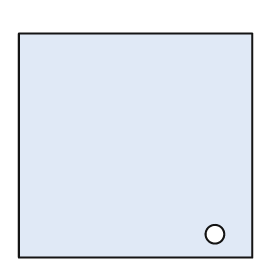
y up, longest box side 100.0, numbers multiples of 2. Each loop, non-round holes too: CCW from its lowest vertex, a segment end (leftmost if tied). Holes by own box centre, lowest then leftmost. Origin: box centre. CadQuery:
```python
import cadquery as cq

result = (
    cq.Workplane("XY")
    .moveTo(-50.0, -48.0)
    .lineTo(50.0, -48.0)
    .lineTo(50.0, 48.0)
    .lineTo(-50.0, 48.0)
    .close()
    .moveTo(34.0, -38.0)
    .circle(4.0)
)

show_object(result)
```